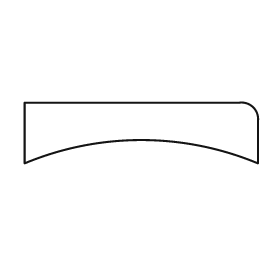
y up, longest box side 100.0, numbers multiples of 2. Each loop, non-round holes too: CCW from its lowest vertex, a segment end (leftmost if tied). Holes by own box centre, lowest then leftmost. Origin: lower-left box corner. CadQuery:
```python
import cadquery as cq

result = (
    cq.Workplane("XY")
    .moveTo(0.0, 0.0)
    .threePointArc((50.0, 10.0), (100.0, 0.0))
    .lineTo(100.0, 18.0)
    .threePointArc((98.0, 24.0), (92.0, 26.0))
    .lineTo(0.0, 26.0)
    .close()
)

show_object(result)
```